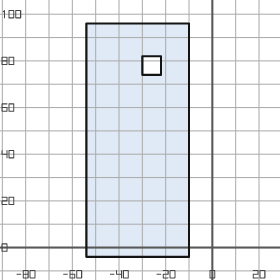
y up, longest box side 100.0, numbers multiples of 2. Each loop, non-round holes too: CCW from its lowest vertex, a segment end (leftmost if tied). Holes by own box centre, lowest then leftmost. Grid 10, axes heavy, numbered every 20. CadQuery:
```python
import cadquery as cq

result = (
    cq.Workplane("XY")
    .moveTo(-54.0, -4.0)
    .lineTo(-10.0, -4.0)
    .lineTo(-10.0, 96.0)
    .lineTo(-54.0, 96.0)
    .close()
    .moveTo(-30.0, 74.0)
    .lineTo(-22.0, 74.0)
    .lineTo(-22.0, 82.0)
    .lineTo(-30.0, 82.0)
    .close()
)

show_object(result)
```